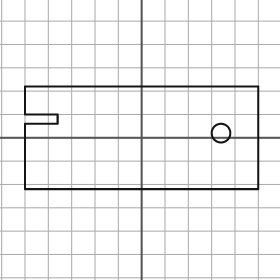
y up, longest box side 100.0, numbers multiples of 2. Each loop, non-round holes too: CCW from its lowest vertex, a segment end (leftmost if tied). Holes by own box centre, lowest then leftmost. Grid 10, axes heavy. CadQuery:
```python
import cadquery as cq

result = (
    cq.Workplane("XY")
    .moveTo(-50.0, -22.0)
    .lineTo(50.0, -22.0)
    .lineTo(50.0, 22.0)
    .lineTo(-50.0, 22.0)
    .lineTo(-50.0, 10.0)
    .lineTo(-36.0, 10.0)
    .lineTo(-36.0, 6.0)
    .lineTo(-50.0, 6.0)
    .close()
    .moveTo(34.0, 2.0)
    .circle(4.0)
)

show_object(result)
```